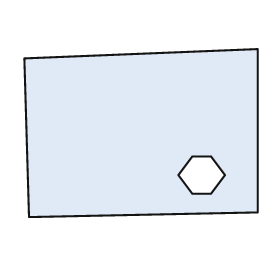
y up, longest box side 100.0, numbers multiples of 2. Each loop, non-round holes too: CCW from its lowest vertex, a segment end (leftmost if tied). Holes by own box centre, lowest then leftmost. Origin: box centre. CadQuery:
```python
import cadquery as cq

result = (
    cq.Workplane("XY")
    .moveTo(-48.0, -36.0)
    .lineTo(50.0, -34.0)
    .lineTo(50.0, 36.0)
    .lineTo(-50.0, 32.0)
    .close()
    .moveTo(22.0, -26.0)
    .lineTo(30.0, -26.0)
    .lineTo(36.0, -18.0)
    .lineTo(30.0, -10.0)
    .lineTo(22.0, -10.0)
    .lineTo(16.0, -18.0)
    .close()
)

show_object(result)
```